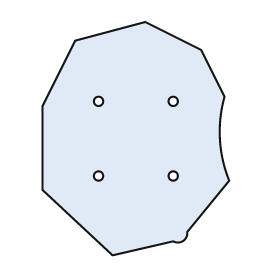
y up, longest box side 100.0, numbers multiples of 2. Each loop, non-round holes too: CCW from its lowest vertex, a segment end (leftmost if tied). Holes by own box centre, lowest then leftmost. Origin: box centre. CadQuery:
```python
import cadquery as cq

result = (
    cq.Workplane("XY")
    .moveTo(-10.0, -50.0)
    .lineTo(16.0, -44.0)
    .threePointArc((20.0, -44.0), (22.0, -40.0))
    .lineTo(40.0, -18.0)
    .threePointArc((36.0, 0.0), (38.0, 18.0))
    .lineTo(28.0, 38.0)
    .lineTo(4.0, 50.0)
    .lineTo(-26.0, 42.0)
    .lineTo(-40.0, 14.0)
    .lineTo(-40.0, -22.0)
    .close()
    .moveTo(-16.0, -16.0)
    .circle(2.0)
    .moveTo(16.0, -16.0)
    .circle(2.0)
    .moveTo(-16.0, 16.0)
    .circle(2.0)
    .moveTo(16.0, 16.0)
    .circle(2.0)
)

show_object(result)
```